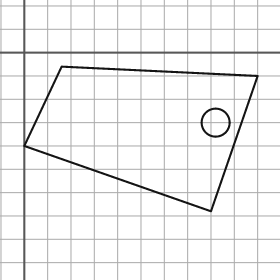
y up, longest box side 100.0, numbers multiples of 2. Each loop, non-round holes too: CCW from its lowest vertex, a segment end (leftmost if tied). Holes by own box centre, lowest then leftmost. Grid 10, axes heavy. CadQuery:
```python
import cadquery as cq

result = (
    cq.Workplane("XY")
    .moveTo(80.0, -68.0)
    .lineTo(100.0, -10.0)
    .lineTo(16.0, -6.0)
    .lineTo(0.0, -40.0)
    .close()
    .moveTo(82.0, -30.0)
    .circle(6.0)
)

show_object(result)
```